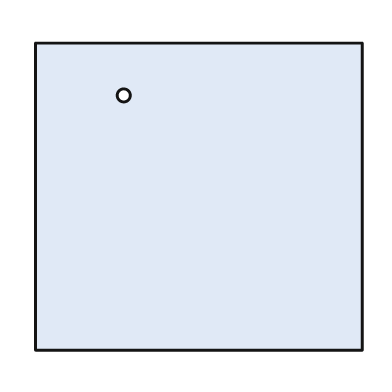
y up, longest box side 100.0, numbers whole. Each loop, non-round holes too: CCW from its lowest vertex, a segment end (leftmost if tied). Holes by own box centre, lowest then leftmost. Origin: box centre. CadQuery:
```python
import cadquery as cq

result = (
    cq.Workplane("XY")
    .moveTo(-50.0, -47.0)
    .lineTo(50.0, -47.0)
    .lineTo(50.0, 47.0)
    .lineTo(-50.0, 47.0)
    .close()
    .moveTo(-23.0, 31.0)
    .circle(2.0)
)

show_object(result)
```